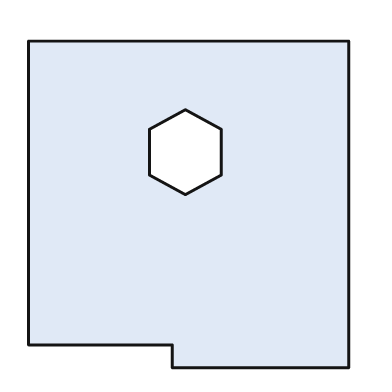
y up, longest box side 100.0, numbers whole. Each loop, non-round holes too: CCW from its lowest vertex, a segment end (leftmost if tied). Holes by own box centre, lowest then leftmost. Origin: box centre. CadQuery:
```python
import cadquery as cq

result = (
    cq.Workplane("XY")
    .moveTo(-5.0, -50.0)
    .lineTo(49.0, -50.0)
    .lineTo(49.0, 50.0)
    .lineTo(-49.0, 50.0)
    .lineTo(-49.0, -43.0)
    .lineTo(-5.0, -43.0)
    .close()
    .moveTo(-1.0, 3.0)
    .lineTo(10.0, 9.0)
    .lineTo(10.0, 23.0)
    .lineTo(-1.0, 29.0)
    .lineTo(-12.0, 23.0)
    .lineTo(-12.0, 9.0)
    .close()
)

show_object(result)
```